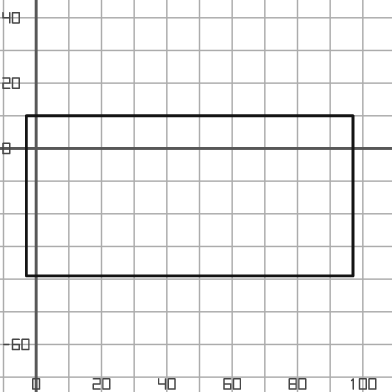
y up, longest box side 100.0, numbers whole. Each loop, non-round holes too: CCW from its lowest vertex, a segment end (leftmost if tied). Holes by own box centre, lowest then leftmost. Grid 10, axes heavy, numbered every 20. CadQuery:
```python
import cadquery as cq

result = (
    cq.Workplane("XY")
    .moveTo(-3.0, -39.0)
    .lineTo(97.0, -39.0)
    .lineTo(97.0, 10.0)
    .lineTo(-3.0, 10.0)
    .close()
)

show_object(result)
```